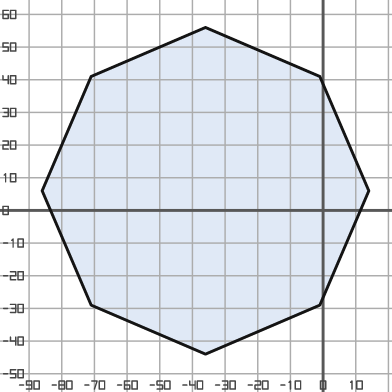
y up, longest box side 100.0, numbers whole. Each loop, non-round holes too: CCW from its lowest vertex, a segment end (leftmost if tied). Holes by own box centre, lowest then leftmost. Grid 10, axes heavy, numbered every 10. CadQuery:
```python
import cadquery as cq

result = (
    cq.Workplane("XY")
    .moveTo(-36.0, -44.0)
    .lineTo(-1.0, -29.0)
    .lineTo(14.0, 6.0)
    .lineTo(-1.0, 41.0)
    .lineTo(-36.0, 56.0)
    .lineTo(-71.0, 41.0)
    .lineTo(-86.0, 6.0)
    .lineTo(-71.0, -29.0)
    .close()
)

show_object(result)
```